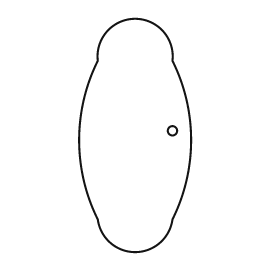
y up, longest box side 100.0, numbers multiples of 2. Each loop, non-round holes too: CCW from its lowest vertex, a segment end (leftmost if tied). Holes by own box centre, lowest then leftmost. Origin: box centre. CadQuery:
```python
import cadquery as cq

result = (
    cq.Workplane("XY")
    .moveTo(-16.0, -36.0)
    .threePointArc((0.0, -50.0), (16.0, -36.0))
    .threePointArc((24.0, -2.0), (16.0, 32.0))
    .threePointArc((0.0, 50.0), (-16.0, 32.0))
    .threePointArc((-24.0, -2.0), (-16.0, -36.0))
    .close()
    .moveTo(16.0, 2.0)
    .circle(2.0)
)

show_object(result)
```